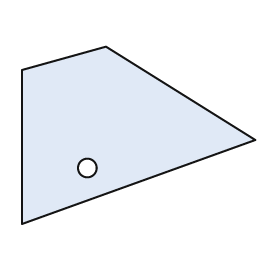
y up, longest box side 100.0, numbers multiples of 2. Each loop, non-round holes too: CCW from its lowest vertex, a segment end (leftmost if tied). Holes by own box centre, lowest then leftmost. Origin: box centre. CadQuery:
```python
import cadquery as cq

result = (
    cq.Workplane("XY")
    .moveTo(-50.0, -38.0)
    .lineTo(50.0, -2.0)
    .lineTo(-14.0, 38.0)
    .lineTo(-50.0, 28.0)
    .close()
    .moveTo(-22.0, -14.0)
    .circle(4.0)
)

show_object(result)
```